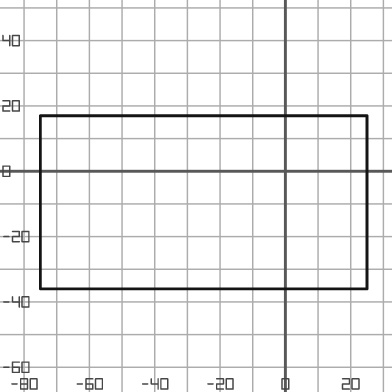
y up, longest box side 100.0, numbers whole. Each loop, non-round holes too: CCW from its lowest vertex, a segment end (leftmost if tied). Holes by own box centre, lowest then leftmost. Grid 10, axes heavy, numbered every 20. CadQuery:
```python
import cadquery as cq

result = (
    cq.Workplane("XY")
    .moveTo(-75.0, -36.0)
    .lineTo(25.0, -36.0)
    .lineTo(25.0, 17.0)
    .lineTo(-75.0, 17.0)
    .close()
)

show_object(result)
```